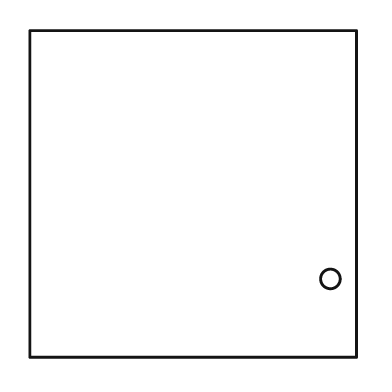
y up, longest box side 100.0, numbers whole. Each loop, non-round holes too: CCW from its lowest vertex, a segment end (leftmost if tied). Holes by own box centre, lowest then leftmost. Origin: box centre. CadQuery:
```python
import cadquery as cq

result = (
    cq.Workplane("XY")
    .moveTo(-50.0, -50.0)
    .lineTo(50.0, -50.0)
    .lineTo(50.0, 50.0)
    .lineTo(-50.0, 50.0)
    .close()
    .moveTo(42.0, -26.0)
    .circle(3.0)
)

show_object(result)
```